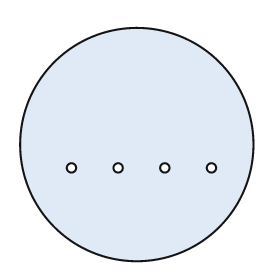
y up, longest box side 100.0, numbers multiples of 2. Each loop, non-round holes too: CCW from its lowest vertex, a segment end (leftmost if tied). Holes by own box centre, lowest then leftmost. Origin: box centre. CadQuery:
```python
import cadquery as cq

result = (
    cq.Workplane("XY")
    .moveTo(0.0, 0.0)
    .circle(50.0)
    .moveTo(-28.0, -10.0)
    .circle(2.0)
    .moveTo(-8.0, -10.0)
    .circle(2.0)
    .moveTo(12.0, -10.0)
    .circle(2.0)
    .moveTo(32.0, -10.0)
    .circle(2.0)
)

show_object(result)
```